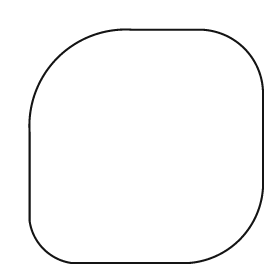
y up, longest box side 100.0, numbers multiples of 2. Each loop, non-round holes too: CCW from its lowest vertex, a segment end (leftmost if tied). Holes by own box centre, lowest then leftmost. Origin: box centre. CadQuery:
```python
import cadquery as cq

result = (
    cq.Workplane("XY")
    .moveTo(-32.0, -50.0)
    .lineTo(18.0, -50.0)
    .threePointArc((40.0, -40.0), (50.0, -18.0))
    .lineTo(50.0, 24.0)
    .threePointArc((42.0, 42.0), (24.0, 50.0))
    .lineTo(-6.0, 50.0)
    .threePointArc((-38.0, 38.0), (-50.0, 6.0))
    .lineTo(-50.0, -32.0)
    .threePointArc((-44.0, -44.0), (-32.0, -50.0))
    .close()
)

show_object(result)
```